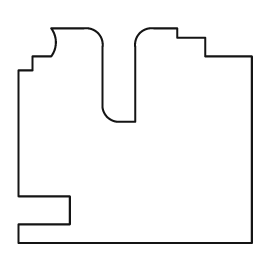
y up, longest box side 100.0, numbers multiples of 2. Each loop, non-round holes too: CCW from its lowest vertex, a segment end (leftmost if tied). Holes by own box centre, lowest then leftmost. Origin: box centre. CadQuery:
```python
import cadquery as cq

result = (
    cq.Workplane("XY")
    .moveTo(-50.0, -46.0)
    .lineTo(50.0, -46.0)
    .lineTo(50.0, 34.0)
    .lineTo(30.0, 34.0)
    .lineTo(30.0, 42.0)
    .lineTo(18.0, 42.0)
    .lineTo(18.0, 46.0)
    .lineTo(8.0, 46.0)
    .threePointArc((2.0, 44.0), (0.0, 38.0))
    .lineTo(0.0, 6.0)
    .lineTo(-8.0, 6.0)
    .threePointArc((-12.0, 8.0), (-14.0, 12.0))
    .lineTo(-14.0, 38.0)
    .threePointArc((-16.0, 44.0), (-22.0, 46.0))
    .lineTo(-36.0, 46.0)
    .threePointArc((-34.0, 40.0), (-36.0, 34.0))
    .lineTo(-44.0, 34.0)
    .lineTo(-44.0, 28.0)
    .lineTo(-50.0, 28.0)
    .lineTo(-50.0, -26.0)
    .lineTo(-28.0, -26.0)
    .lineTo(-28.0, -38.0)
    .lineTo(-50.0, -38.0)
    .close()
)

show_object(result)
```